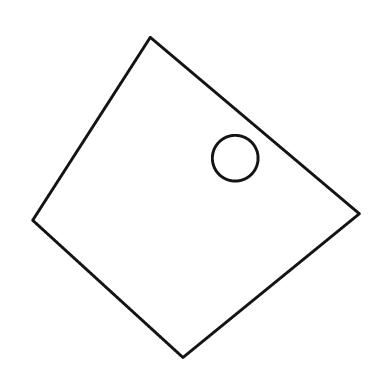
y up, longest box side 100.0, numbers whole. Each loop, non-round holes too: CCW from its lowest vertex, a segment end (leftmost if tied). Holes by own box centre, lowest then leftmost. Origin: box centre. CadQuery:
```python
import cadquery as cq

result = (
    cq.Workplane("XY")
    .moveTo(-4.0, -49.0)
    .lineTo(50.0, -5.0)
    .lineTo(-14.0, 49.0)
    .lineTo(-50.0, -7.0)
    .close()
    .moveTo(12.0, 12.0)
    .circle(7.0)
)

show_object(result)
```